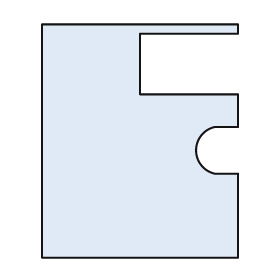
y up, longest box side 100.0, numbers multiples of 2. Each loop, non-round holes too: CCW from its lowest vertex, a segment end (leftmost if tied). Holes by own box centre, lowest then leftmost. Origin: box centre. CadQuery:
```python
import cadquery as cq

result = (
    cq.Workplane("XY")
    .moveTo(-42.0, -50.0)
    .lineTo(42.0, -50.0)
    .lineTo(42.0, -14.0)
    .lineTo(32.0, -14.0)
    .threePointArc((24.0, -4.0), (32.0, 6.0))
    .lineTo(42.0, 6.0)
    .lineTo(42.0, 20.0)
    .lineTo(0.0, 20.0)
    .lineTo(0.0, 46.0)
    .lineTo(42.0, 46.0)
    .lineTo(42.0, 50.0)
    .lineTo(-42.0, 50.0)
    .close()
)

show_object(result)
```